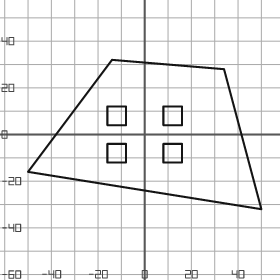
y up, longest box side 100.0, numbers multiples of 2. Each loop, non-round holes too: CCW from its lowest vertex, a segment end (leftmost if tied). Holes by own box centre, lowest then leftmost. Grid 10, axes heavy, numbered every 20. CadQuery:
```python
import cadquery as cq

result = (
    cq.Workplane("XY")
    .moveTo(50.0, -32.0)
    .lineTo(34.0, 28.0)
    .lineTo(-14.0, 32.0)
    .lineTo(-50.0, -16.0)
    .close()
    .moveTo(-16.0, -12.0)
    .lineTo(-8.0, -12.0)
    .lineTo(-8.0, -4.0)
    .lineTo(-16.0, -4.0)
    .close()
    .moveTo(8.0, -12.0)
    .lineTo(16.0, -12.0)
    .lineTo(16.0, -4.0)
    .lineTo(8.0, -4.0)
    .close()
    .moveTo(-16.0, 4.0)
    .lineTo(-8.0, 4.0)
    .lineTo(-8.0, 12.0)
    .lineTo(-16.0, 12.0)
    .close()
    .moveTo(8.0, 4.0)
    .lineTo(16.0, 4.0)
    .lineTo(16.0, 12.0)
    .lineTo(8.0, 12.0)
    .close()
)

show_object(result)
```